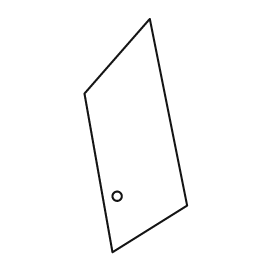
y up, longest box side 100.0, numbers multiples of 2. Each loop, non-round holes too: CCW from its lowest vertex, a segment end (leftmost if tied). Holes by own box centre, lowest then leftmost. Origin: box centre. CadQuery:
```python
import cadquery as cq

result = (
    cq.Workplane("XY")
    .moveTo(-10.0, -50.0)
    .lineTo(22.0, -30.0)
    .lineTo(6.0, 50.0)
    .lineTo(-22.0, 18.0)
    .close()
    .moveTo(-8.0, -26.0)
    .circle(2.0)
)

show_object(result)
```